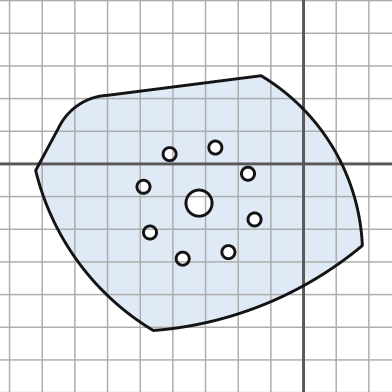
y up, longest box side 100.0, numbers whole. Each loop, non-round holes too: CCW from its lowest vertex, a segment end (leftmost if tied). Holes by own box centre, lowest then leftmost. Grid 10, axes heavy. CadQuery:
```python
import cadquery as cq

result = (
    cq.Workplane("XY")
    .moveTo(-46.0, -51.0)
    .threePointArc((-12.0, -43.0), (18.0, -25.0))
    .threePointArc((9.0, 5.0), (-13.0, 27.0))
    .lineTo(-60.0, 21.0)
    .threePointArc((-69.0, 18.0), (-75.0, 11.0))
    .lineTo(-82.0, -2.0)
    .threePointArc((-69.0, -30.0), (-46.0, -51.0))
    .close()
    .moveTo(-37.0, -29.0)
    .circle(2.0)
    .moveTo(-23.0, -27.0)
    .circle(2.0)
    .moveTo(-47.0, -21.0)
    .circle(2.0)
    .moveTo(-15.0, -17.0)
    .circle(2.0)
    .moveTo(-32.0, -12.0)
    .circle(4.0)
    .moveTo(-49.0, -7.0)
    .circle(2.0)
    .moveTo(-17.0, -3.0)
    .circle(2.0)
    .moveTo(-41.0, 3.0)
    .circle(2.0)
    .moveTo(-27.0, 5.0)
    .circle(2.0)
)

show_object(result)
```